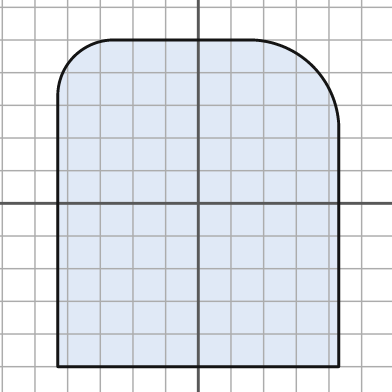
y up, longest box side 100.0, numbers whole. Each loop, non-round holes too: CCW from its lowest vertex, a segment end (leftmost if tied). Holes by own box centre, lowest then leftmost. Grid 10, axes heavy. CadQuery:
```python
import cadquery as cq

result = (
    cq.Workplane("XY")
    .moveTo(-43.0, -50.0)
    .lineTo(43.0, -50.0)
    .lineTo(43.0, 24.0)
    .threePointArc((35.0, 42.0), (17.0, 50.0))
    .lineTo(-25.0, 50.0)
    .threePointArc((-38.0, 45.0), (-43.0, 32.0))
    .close()
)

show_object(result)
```